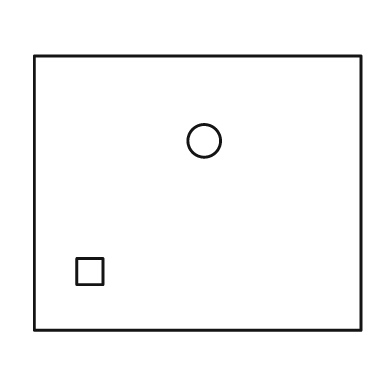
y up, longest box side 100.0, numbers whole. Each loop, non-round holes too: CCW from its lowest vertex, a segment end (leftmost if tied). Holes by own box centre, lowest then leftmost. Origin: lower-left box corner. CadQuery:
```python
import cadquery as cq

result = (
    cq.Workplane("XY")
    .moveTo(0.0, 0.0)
    .lineTo(100.0, 0.0)
    .lineTo(100.0, 84.0)
    .lineTo(0.0, 84.0)
    .close()
    .moveTo(13.0, 14.0)
    .lineTo(21.0, 14.0)
    .lineTo(21.0, 22.0)
    .lineTo(13.0, 22.0)
    .close()
    .moveTo(52.0, 58.0)
    .circle(5.0)
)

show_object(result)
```